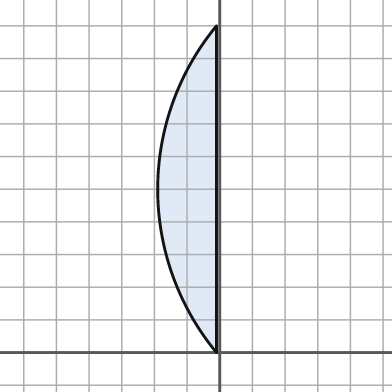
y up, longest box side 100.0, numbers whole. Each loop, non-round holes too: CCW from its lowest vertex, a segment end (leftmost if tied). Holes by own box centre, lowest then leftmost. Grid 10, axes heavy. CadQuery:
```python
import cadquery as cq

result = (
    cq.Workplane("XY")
    .moveTo(-1.0, 0.0)
    .lineTo(-1.0, 100.0)
    .threePointArc((-19.0, 50.0), (-1.0, 0.0))
    .close()
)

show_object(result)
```